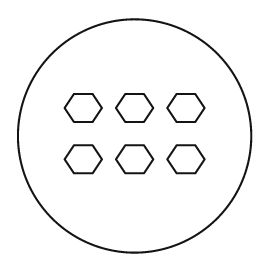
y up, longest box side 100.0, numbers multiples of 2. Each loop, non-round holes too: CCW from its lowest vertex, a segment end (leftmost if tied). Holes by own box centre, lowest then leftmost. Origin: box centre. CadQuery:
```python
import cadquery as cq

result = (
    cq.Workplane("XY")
    .moveTo(0.0, 0.0)
    .circle(50.0)
    .moveTo(-26.0, -16.0)
    .lineTo(-18.0, -16.0)
    .lineTo(-14.0, -10.0)
    .lineTo(-18.0, -4.0)
    .lineTo(-26.0, -4.0)
    .lineTo(-30.0, -10.0)
    .close()
    .moveTo(-4.0, -16.0)
    .lineTo(4.0, -16.0)
    .lineTo(8.0, -10.0)
    .lineTo(4.0, -4.0)
    .lineTo(-4.0, -4.0)
    .lineTo(-8.0, -10.0)
    .close()
    .moveTo(18.0, -16.0)
    .lineTo(26.0, -16.0)
    .lineTo(30.0, -10.0)
    .lineTo(26.0, -4.0)
    .lineTo(18.0, -4.0)
    .lineTo(14.0, -10.0)
    .close()
    .moveTo(-26.0, 6.0)
    .lineTo(-18.0, 6.0)
    .lineTo(-14.0, 12.0)
    .lineTo(-18.0, 18.0)
    .lineTo(-26.0, 18.0)
    .lineTo(-30.0, 12.0)
    .close()
    .moveTo(-4.0, 6.0)
    .lineTo(4.0, 6.0)
    .lineTo(8.0, 12.0)
    .lineTo(4.0, 18.0)
    .lineTo(-4.0, 18.0)
    .lineTo(-8.0, 12.0)
    .close()
    .moveTo(18.0, 6.0)
    .lineTo(26.0, 6.0)
    .lineTo(30.0, 12.0)
    .lineTo(26.0, 18.0)
    .lineTo(18.0, 18.0)
    .lineTo(14.0, 12.0)
    .close()
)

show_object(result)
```